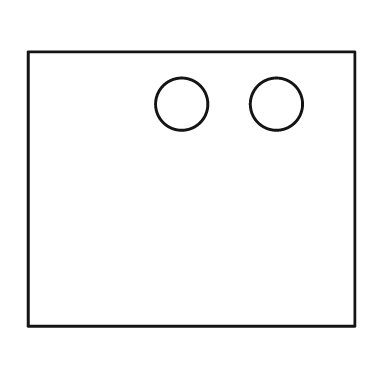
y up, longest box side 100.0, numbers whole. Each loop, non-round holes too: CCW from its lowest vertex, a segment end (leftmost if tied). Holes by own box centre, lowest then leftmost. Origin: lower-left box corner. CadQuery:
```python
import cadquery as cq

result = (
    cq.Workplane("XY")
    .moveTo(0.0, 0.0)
    .lineTo(100.0, 0.0)
    .lineTo(100.0, 84.0)
    .lineTo(0.0, 84.0)
    .close()
    .moveTo(47.0, 68.0)
    .circle(8.0)
    .moveTo(76.0, 68.0)
    .circle(8.0)
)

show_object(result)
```